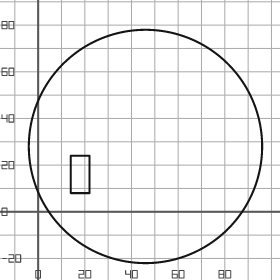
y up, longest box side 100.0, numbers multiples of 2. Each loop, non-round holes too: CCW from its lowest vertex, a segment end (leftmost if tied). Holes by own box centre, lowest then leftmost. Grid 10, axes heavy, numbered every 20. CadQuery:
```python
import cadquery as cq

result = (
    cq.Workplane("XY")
    .moveTo(46.0, 28.0)
    .circle(50.0)
    .moveTo(14.0, 8.0)
    .lineTo(22.0, 8.0)
    .lineTo(22.0, 24.0)
    .lineTo(14.0, 24.0)
    .close()
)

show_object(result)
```